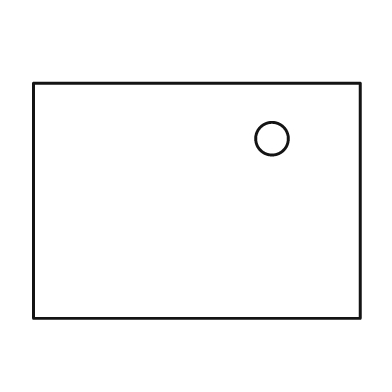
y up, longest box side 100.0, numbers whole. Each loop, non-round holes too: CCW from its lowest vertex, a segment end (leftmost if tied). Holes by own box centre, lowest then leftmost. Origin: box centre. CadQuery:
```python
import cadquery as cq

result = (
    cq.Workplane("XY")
    .moveTo(-50.0, -36.0)
    .lineTo(50.0, -36.0)
    .lineTo(50.0, 36.0)
    .lineTo(-50.0, 36.0)
    .close()
    .moveTo(23.0, 19.0)
    .circle(5.0)
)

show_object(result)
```